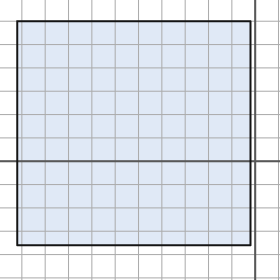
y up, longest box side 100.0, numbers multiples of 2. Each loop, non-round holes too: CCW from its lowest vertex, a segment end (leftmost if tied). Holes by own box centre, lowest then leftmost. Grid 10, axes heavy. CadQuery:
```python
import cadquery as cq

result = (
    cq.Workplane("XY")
    .moveTo(-102.0, -36.0)
    .lineTo(-2.0, -36.0)
    .lineTo(-2.0, 60.0)
    .lineTo(-102.0, 60.0)
    .close()
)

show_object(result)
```